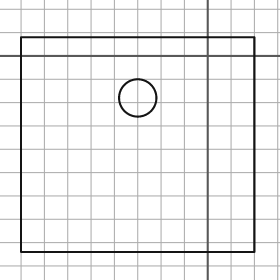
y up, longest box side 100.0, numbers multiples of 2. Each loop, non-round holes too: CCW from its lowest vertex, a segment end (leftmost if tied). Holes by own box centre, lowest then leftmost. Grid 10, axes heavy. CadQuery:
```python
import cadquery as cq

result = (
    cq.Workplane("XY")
    .moveTo(-80.0, -84.0)
    .lineTo(20.0, -84.0)
    .lineTo(20.0, 8.0)
    .lineTo(-80.0, 8.0)
    .close()
    .moveTo(-30.0, -18.0)
    .circle(8.0)
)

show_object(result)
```